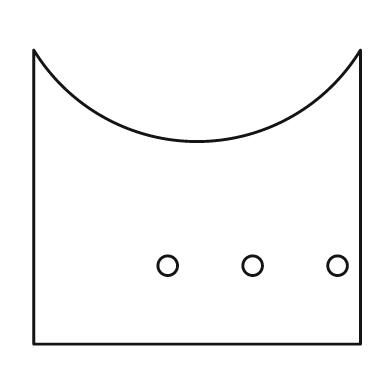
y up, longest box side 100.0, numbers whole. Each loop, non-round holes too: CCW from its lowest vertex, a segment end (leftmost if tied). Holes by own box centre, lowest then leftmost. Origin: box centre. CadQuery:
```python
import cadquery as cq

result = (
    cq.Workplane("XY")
    .moveTo(-50.0, -45.0)
    .lineTo(50.0, -45.0)
    .lineTo(50.0, 45.0)
    .threePointArc((0.0, 17.0), (-50.0, 45.0))
    .close()
    .moveTo(-9.0, -21.0)
    .circle(3.0)
    .moveTo(17.0, -21.0)
    .circle(3.0)
    .moveTo(43.0, -21.0)
    .circle(3.0)
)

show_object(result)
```